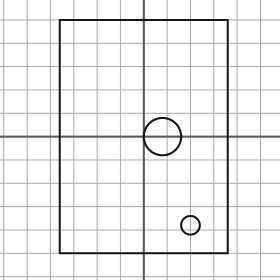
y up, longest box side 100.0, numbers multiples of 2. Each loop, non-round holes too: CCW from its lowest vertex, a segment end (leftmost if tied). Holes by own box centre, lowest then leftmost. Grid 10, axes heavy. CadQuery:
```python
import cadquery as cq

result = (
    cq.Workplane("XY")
    .moveTo(-36.0, -50.0)
    .lineTo(36.0, -50.0)
    .lineTo(36.0, 50.0)
    .lineTo(-36.0, 50.0)
    .close()
    .moveTo(20.0, -38.0)
    .circle(4.0)
    .moveTo(8.0, 0.0)
    .circle(8.0)
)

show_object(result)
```